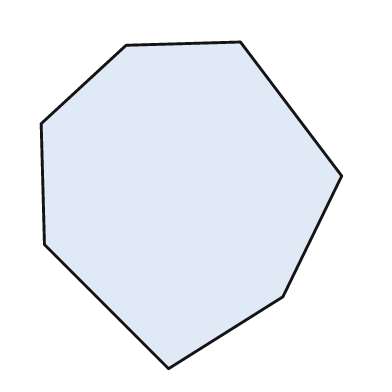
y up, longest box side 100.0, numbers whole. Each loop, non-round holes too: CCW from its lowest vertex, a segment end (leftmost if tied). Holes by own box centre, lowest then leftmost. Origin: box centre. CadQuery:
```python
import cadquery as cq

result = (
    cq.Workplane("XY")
    .moveTo(-7.0, -50.0)
    .lineTo(28.0, -28.0)
    .lineTo(46.0, 9.0)
    .lineTo(15.0, 50.0)
    .lineTo(-20.0, 49.0)
    .lineTo(-46.0, 25.0)
    .lineTo(-45.0, -12.0)
    .close()
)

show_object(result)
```